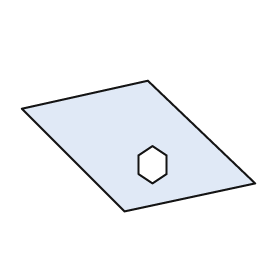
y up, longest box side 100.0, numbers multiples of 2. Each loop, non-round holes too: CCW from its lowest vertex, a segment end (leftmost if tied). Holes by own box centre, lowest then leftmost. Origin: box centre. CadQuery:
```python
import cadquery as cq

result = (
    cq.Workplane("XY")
    .moveTo(-6.0, -28.0)
    .lineTo(50.0, -16.0)
    .lineTo(4.0, 28.0)
    .lineTo(-50.0, 16.0)
    .close()
    .moveTo(6.0, -16.0)
    .lineTo(12.0, -12.0)
    .lineTo(12.0, -4.0)
    .lineTo(6.0, 0.0)
    .lineTo(0.0, -4.0)
    .lineTo(0.0, -12.0)
    .close()
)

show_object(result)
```